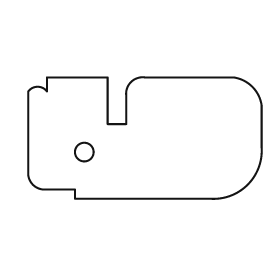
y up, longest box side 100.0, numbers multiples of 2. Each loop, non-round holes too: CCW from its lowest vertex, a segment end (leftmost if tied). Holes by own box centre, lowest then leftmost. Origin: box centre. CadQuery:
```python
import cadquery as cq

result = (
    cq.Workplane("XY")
    .moveTo(-30.0, -26.0)
    .lineTo(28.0, -26.0)
    .threePointArc((44.0, -20.0), (50.0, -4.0))
    .lineTo(50.0, 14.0)
    .threePointArc((46.0, 22.0), (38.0, 26.0))
    .lineTo(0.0, 26.0)
    .threePointArc((-6.0, 24.0), (-8.0, 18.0))
    .lineTo(-8.0, 6.0)
    .lineTo(-16.0, 6.0)
    .lineTo(-16.0, 26.0)
    .lineTo(-42.0, 26.0)
    .lineTo(-42.0, 20.0)
    .threePointArc((-46.0, 22.0), (-50.0, 20.0))
    .lineTo(-50.0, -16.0)
    .threePointArc((-48.0, -20.0), (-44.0, -22.0))
    .lineTo(-30.0, -22.0)
    .close()
    .moveTo(-26.0, -6.0)
    .circle(4.0)
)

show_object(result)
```